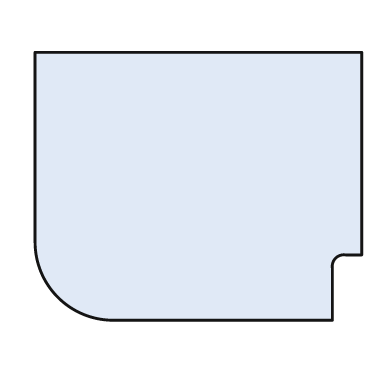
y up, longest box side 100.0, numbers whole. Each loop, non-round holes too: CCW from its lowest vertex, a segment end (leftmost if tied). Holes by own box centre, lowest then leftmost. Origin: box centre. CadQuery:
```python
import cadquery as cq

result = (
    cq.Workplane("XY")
    .moveTo(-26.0, -41.0)
    .lineTo(41.0, -41.0)
    .lineTo(41.0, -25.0)
    .threePointArc((42.0, -22.0), (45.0, -21.0))
    .lineTo(50.0, -21.0)
    .lineTo(50.0, 41.0)
    .lineTo(-50.0, 41.0)
    .lineTo(-50.0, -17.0)
    .threePointArc((-43.0, -34.0), (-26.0, -41.0))
    .close()
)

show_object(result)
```